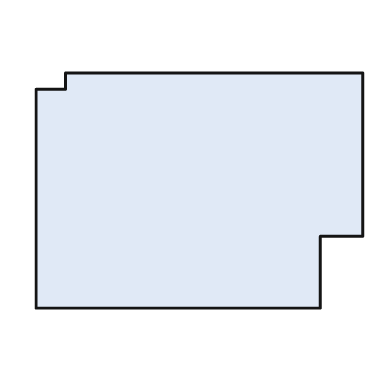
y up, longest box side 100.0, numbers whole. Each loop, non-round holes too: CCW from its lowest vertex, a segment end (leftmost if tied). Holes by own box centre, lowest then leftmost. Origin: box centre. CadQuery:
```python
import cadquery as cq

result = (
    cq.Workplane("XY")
    .moveTo(-50.0, -36.0)
    .lineTo(37.0, -36.0)
    .lineTo(37.0, -14.0)
    .lineTo(50.0, -14.0)
    .lineTo(50.0, 36.0)
    .lineTo(-41.0, 36.0)
    .lineTo(-41.0, 31.0)
    .lineTo(-50.0, 31.0)
    .close()
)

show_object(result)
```